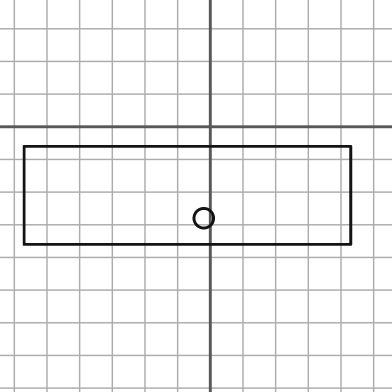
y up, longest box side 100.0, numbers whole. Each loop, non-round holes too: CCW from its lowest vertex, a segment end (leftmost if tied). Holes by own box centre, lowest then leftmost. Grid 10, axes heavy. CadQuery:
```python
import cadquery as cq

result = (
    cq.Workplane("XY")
    .moveTo(-57.0, -36.0)
    .lineTo(43.0, -36.0)
    .lineTo(43.0, -6.0)
    .lineTo(-57.0, -6.0)
    .close()
    .moveTo(-2.0, -28.0)
    .circle(3.0)
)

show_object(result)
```